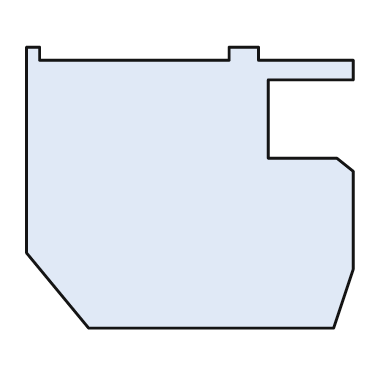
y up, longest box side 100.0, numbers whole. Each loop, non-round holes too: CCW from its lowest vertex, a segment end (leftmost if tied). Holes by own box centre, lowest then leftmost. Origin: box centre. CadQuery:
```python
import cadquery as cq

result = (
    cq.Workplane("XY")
    .moveTo(-31.0, -43.0)
    .lineTo(44.0, -43.0)
    .lineTo(50.0, -25.0)
    .lineTo(50.0, 5.0)
    .lineTo(45.0, 9.0)
    .lineTo(24.0, 9.0)
    .lineTo(24.0, 33.0)
    .lineTo(50.0, 33.0)
    .lineTo(50.0, 39.0)
    .lineTo(21.0, 39.0)
    .lineTo(21.0, 43.0)
    .lineTo(12.0, 43.0)
    .lineTo(12.0, 39.0)
    .lineTo(-46.0, 39.0)
    .lineTo(-46.0, 43.0)
    .lineTo(-50.0, 43.0)
    .lineTo(-50.0, -20.0)
    .close()
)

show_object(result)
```